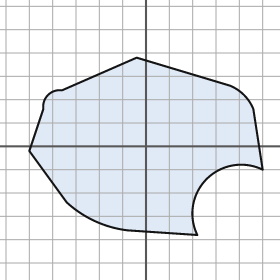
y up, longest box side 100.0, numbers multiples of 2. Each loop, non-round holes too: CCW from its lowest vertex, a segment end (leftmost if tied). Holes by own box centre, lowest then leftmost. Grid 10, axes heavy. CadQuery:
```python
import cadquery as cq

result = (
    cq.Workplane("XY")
    .moveTo(22.0, -38.0)
    .threePointArc((26.0, -14.0), (50.0, -10.0))
    .lineTo(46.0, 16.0)
    .threePointArc((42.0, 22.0), (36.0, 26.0))
    .lineTo(-4.0, 38.0)
    .lineTo(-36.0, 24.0)
    .threePointArc((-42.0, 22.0), (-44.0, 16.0))
    .lineTo(-50.0, -2.0)
    .lineTo(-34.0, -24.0)
    .threePointArc((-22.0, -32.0), (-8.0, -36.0))
    .close()
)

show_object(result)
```